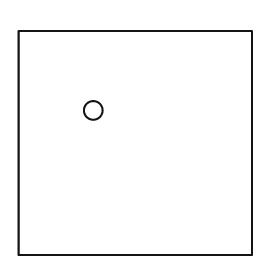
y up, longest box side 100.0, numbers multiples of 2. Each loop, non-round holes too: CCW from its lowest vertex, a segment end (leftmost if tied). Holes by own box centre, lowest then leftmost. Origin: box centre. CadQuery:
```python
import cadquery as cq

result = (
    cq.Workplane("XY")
    .moveTo(-50.0, -48.0)
    .lineTo(50.0, -48.0)
    .lineTo(50.0, 48.0)
    .lineTo(-50.0, 48.0)
    .close()
    .moveTo(-18.0, 14.0)
    .circle(4.0)
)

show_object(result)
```